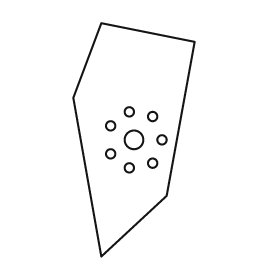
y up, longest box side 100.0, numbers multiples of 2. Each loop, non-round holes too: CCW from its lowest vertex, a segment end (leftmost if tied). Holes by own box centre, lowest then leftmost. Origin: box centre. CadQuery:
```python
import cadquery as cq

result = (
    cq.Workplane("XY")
    .moveTo(-14.0, -50.0)
    .lineTo(14.0, -24.0)
    .lineTo(26.0, 42.0)
    .lineTo(-14.0, 50.0)
    .lineTo(-26.0, 18.0)
    .close()
    .moveTo(-2.0, -12.0)
    .circle(2.0)
    .moveTo(8.0, -10.0)
    .circle(2.0)
    .moveTo(-10.0, -6.0)
    .circle(2.0)
    .moveTo(0.0, 0.0)
    .circle(4.0)
    .moveTo(12.0, 0.0)
    .circle(2.0)
    .moveTo(-10.0, 6.0)
    .circle(2.0)
    .moveTo(8.0, 10.0)
    .circle(2.0)
    .moveTo(-2.0, 12.0)
    .circle(2.0)
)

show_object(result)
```